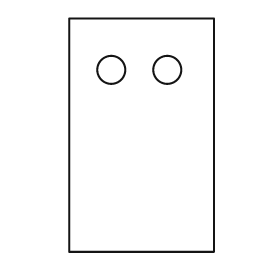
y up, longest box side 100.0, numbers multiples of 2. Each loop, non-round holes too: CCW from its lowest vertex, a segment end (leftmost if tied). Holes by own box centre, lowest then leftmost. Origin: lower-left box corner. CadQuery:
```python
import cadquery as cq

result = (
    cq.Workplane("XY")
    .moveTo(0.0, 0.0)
    .lineTo(62.0, 0.0)
    .lineTo(62.0, 100.0)
    .lineTo(0.0, 100.0)
    .close()
    .moveTo(18.0, 78.0)
    .circle(6.0)
    .moveTo(42.0, 78.0)
    .circle(6.0)
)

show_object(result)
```